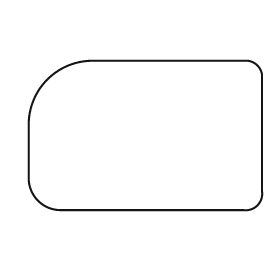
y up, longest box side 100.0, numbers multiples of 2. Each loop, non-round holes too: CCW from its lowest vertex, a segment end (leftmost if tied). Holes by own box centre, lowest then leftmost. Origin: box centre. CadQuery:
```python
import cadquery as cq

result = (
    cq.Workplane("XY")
    .moveTo(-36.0, -32.0)
    .lineTo(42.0, -32.0)
    .threePointArc((48.0, -30.0), (50.0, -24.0))
    .lineTo(50.0, 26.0)
    .threePointArc((48.0, 30.0), (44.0, 32.0))
    .lineTo(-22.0, 32.0)
    .threePointArc((-42.0, 24.0), (-50.0, 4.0))
    .lineTo(-50.0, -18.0)
    .threePointArc((-46.0, -28.0), (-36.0, -32.0))
    .close()
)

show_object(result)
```